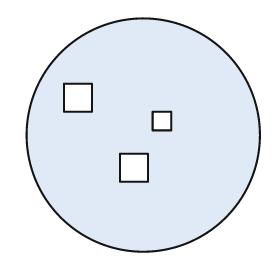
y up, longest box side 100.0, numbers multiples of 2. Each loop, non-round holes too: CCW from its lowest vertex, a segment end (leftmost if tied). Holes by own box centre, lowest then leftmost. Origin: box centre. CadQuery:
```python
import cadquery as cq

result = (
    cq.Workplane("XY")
    .moveTo(0.0, 0.0)
    .circle(50.0)
    .moveTo(-10.0, -20.0)
    .lineTo(2.0, -20.0)
    .lineTo(2.0, -8.0)
    .lineTo(-10.0, -8.0)
    .close()
    .moveTo(4.0, 2.0)
    .lineTo(12.0, 2.0)
    .lineTo(12.0, 10.0)
    .lineTo(4.0, 10.0)
    .close()
    .moveTo(-34.0, 10.0)
    .lineTo(-22.0, 10.0)
    .lineTo(-22.0, 22.0)
    .lineTo(-34.0, 22.0)
    .close()
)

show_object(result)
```